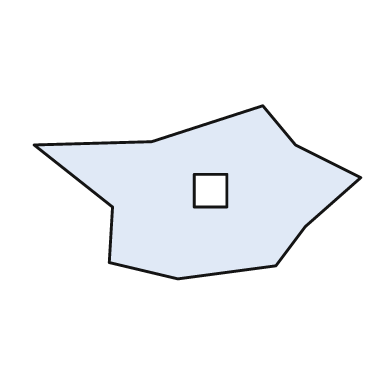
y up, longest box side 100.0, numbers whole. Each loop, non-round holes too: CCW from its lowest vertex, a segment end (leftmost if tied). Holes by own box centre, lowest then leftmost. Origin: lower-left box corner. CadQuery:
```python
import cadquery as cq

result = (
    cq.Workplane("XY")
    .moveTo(44.0, 0.0)
    .lineTo(74.0, 4.0)
    .lineTo(83.0, 16.0)
    .lineTo(100.0, 31.0)
    .lineTo(80.0, 41.0)
    .lineTo(70.0, 53.0)
    .lineTo(36.0, 42.0)
    .lineTo(0.0, 41.0)
    .lineTo(24.0, 22.0)
    .lineTo(23.0, 5.0)
    .close()
    .moveTo(49.0, 22.0)
    .lineTo(59.0, 22.0)
    .lineTo(59.0, 32.0)
    .lineTo(49.0, 32.0)
    .close()
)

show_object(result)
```